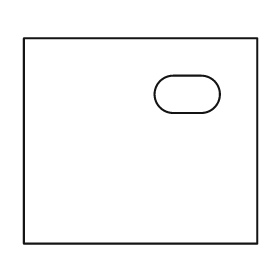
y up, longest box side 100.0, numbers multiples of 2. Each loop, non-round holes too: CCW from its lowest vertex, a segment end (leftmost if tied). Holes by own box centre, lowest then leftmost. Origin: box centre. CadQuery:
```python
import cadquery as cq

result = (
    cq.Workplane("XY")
    .moveTo(-50.0, -44.0)
    .lineTo(50.0, -44.0)
    .lineTo(50.0, 44.0)
    .lineTo(-50.0, 44.0)
    .close()
    .moveTo(14.0, 12.0)
    .lineTo(26.0, 12.0)
    .threePointArc((34.0, 20.0), (26.0, 28.0))
    .lineTo(14.0, 28.0)
    .threePointArc((6.0, 20.0), (14.0, 12.0))
    .close()
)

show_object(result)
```